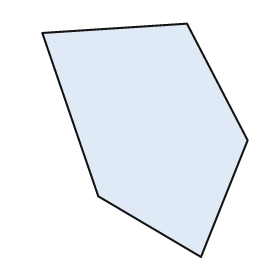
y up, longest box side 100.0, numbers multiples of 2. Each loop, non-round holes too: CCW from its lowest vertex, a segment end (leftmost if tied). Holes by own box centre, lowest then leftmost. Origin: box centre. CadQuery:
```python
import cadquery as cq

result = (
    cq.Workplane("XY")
    .moveTo(24.0, -50.0)
    .lineTo(44.0, 0.0)
    .lineTo(18.0, 50.0)
    .lineTo(-44.0, 46.0)
    .lineTo(-20.0, -24.0)
    .close()
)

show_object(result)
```